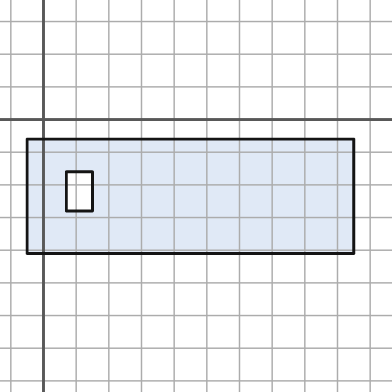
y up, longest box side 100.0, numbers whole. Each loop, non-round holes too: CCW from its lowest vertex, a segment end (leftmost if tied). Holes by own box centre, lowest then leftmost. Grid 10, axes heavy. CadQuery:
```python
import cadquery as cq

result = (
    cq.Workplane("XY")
    .moveTo(-5.0, -41.0)
    .lineTo(95.0, -41.0)
    .lineTo(95.0, -6.0)
    .lineTo(-5.0, -6.0)
    .close()
    .moveTo(7.0, -28.0)
    .lineTo(15.0, -28.0)
    .lineTo(15.0, -16.0)
    .lineTo(7.0, -16.0)
    .close()
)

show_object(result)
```